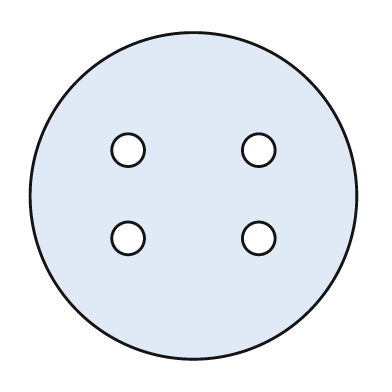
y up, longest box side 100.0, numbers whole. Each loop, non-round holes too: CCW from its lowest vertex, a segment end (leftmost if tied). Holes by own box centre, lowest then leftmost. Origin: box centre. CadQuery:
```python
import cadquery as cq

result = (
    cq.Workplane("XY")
    .moveTo(0.0, 0.0)
    .circle(50.0)
    .moveTo(-20.0, -13.0)
    .circle(5.0)
    .moveTo(20.0, -13.0)
    .circle(5.0)
    .moveTo(-20.0, 14.0)
    .circle(5.0)
    .moveTo(20.0, 14.0)
    .circle(5.0)
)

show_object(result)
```